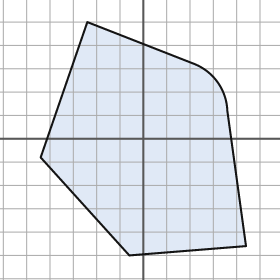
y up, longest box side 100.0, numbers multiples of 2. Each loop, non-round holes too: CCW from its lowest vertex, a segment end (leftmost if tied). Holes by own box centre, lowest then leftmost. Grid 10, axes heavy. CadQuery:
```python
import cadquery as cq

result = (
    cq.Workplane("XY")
    .moveTo(-6.0, -50.0)
    .lineTo(44.0, -46.0)
    .lineTo(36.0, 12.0)
    .threePointArc((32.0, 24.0), (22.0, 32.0))
    .lineTo(-24.0, 50.0)
    .lineTo(-44.0, -8.0)
    .close()
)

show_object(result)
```